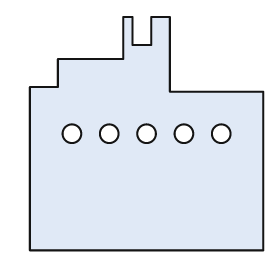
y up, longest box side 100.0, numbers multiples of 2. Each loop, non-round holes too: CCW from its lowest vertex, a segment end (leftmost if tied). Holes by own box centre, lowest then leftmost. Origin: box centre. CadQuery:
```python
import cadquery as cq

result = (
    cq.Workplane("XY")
    .moveTo(-50.0, -50.0)
    .lineTo(50.0, -50.0)
    .lineTo(50.0, 18.0)
    .lineTo(10.0, 18.0)
    .lineTo(10.0, 50.0)
    .lineTo(2.0, 50.0)
    .lineTo(2.0, 38.0)
    .lineTo(-6.0, 38.0)
    .lineTo(-6.0, 50.0)
    .lineTo(-10.0, 50.0)
    .lineTo(-10.0, 32.0)
    .lineTo(-38.0, 32.0)
    .lineTo(-38.0, 20.0)
    .lineTo(-50.0, 20.0)
    .close()
    .moveTo(-32.0, 0.0)
    .circle(4.0)
    .moveTo(-16.0, 0.0)
    .circle(4.0)
    .moveTo(0.0, 0.0)
    .circle(4.0)
    .moveTo(16.0, 0.0)
    .circle(4.0)
    .moveTo(32.0, 0.0)
    .circle(4.0)
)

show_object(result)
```